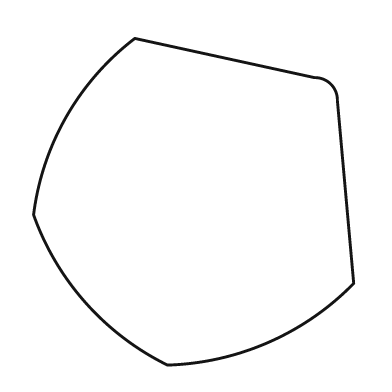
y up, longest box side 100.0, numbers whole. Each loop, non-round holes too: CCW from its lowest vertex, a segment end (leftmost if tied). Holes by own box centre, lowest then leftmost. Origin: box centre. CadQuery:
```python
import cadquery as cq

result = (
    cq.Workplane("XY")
    .moveTo(-8.0, -50.0)
    .threePointArc((23.0, -43.0), (49.0, -25.0))
    .lineTo(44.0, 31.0)
    .threePointArc((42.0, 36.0), (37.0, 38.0))
    .lineTo(-18.0, 50.0)
    .threePointArc((-39.0, 26.0), (-49.0, -4.0))
    .threePointArc((-33.0, -31.0), (-8.0, -50.0))
    .close()
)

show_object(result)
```